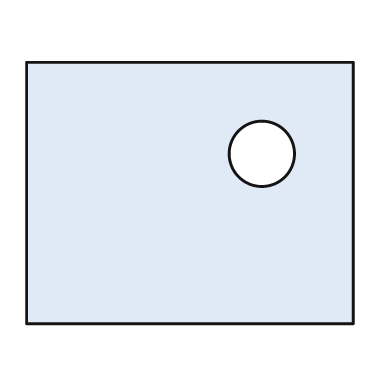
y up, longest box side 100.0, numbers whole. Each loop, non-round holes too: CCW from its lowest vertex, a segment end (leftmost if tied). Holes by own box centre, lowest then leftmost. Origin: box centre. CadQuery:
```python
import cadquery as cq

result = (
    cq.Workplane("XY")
    .moveTo(-50.0, -40.0)
    .lineTo(50.0, -40.0)
    .lineTo(50.0, 40.0)
    .lineTo(-50.0, 40.0)
    .close()
    .moveTo(22.0, 12.0)
    .circle(10.0)
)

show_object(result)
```